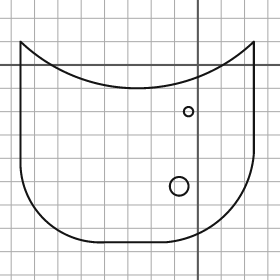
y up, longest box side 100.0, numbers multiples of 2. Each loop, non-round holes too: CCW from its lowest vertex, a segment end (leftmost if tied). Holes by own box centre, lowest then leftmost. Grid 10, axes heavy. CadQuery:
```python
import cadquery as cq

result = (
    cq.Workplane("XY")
    .moveTo(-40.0, -76.0)
    .lineTo(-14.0, -76.0)
    .threePointArc((12.0, -64.0), (24.0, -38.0))
    .lineTo(24.0, 10.0)
    .threePointArc((-26.0, -10.0), (-76.0, 10.0))
    .lineTo(-76.0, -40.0)
    .threePointArc((-66.0, -66.0), (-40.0, -76.0))
    .close()
    .moveTo(-8.0, -52.0)
    .circle(4.0)
    .moveTo(-4.0, -20.0)
    .circle(2.0)
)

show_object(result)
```